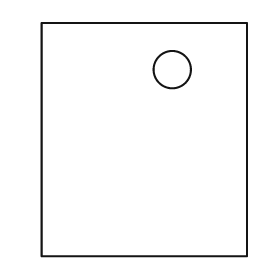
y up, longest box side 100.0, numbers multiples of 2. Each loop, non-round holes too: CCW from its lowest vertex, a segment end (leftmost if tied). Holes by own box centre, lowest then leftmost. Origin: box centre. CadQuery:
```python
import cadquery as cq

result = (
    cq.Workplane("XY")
    .moveTo(-44.0, -50.0)
    .lineTo(44.0, -50.0)
    .lineTo(44.0, 50.0)
    .lineTo(-44.0, 50.0)
    .close()
    .moveTo(12.0, 30.0)
    .circle(8.0)
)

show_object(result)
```